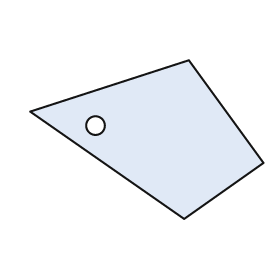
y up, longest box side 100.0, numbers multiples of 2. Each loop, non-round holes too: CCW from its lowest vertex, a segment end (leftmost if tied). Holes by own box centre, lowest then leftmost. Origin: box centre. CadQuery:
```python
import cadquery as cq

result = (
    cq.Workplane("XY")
    .moveTo(16.0, -34.0)
    .lineTo(50.0, -10.0)
    .lineTo(18.0, 34.0)
    .lineTo(-50.0, 12.0)
    .close()
    .moveTo(-22.0, 6.0)
    .circle(4.0)
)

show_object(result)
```